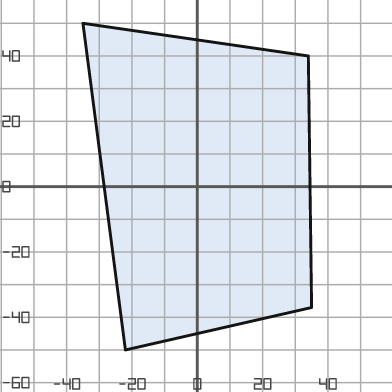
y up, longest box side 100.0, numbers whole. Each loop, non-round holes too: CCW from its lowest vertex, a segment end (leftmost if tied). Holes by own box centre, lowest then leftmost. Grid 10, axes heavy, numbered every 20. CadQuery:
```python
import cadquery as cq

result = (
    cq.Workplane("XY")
    .moveTo(-22.0, -50.0)
    .lineTo(35.0, -37.0)
    .lineTo(34.0, 40.0)
    .lineTo(-35.0, 50.0)
    .close()
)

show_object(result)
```